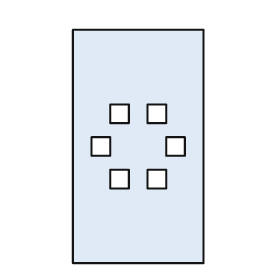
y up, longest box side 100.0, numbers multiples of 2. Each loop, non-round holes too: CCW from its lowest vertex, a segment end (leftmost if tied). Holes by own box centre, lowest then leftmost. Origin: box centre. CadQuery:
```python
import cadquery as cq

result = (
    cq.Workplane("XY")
    .moveTo(-28.0, -50.0)
    .lineTo(28.0, -50.0)
    .lineTo(28.0, 50.0)
    .lineTo(-28.0, 50.0)
    .close()
    .moveTo(-12.0, -18.0)
    .lineTo(-4.0, -18.0)
    .lineTo(-4.0, -10.0)
    .lineTo(-12.0, -10.0)
    .close()
    .moveTo(4.0, -18.0)
    .lineTo(12.0, -18.0)
    .lineTo(12.0, -10.0)
    .lineTo(4.0, -10.0)
    .close()
    .moveTo(-20.0, -4.0)
    .lineTo(-12.0, -4.0)
    .lineTo(-12.0, 4.0)
    .lineTo(-20.0, 4.0)
    .close()
    .moveTo(12.0, -4.0)
    .lineTo(20.0, -4.0)
    .lineTo(20.0, 4.0)
    .lineTo(12.0, 4.0)
    .close()
    .moveTo(-12.0, 10.0)
    .lineTo(-4.0, 10.0)
    .lineTo(-4.0, 18.0)
    .lineTo(-12.0, 18.0)
    .close()
    .moveTo(4.0, 10.0)
    .lineTo(12.0, 10.0)
    .lineTo(12.0, 18.0)
    .lineTo(4.0, 18.0)
    .close()
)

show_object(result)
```